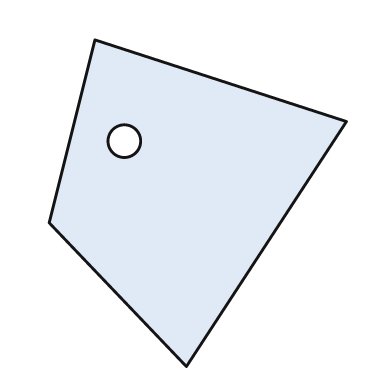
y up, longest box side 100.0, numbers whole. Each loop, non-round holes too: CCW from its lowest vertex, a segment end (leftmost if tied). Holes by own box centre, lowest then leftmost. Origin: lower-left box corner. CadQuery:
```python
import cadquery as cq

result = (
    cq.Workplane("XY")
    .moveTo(42.0, 0.0)
    .lineTo(91.0, 75.0)
    .lineTo(14.0, 100.0)
    .lineTo(0.0, 44.0)
    .close()
    .moveTo(23.0, 69.0)
    .circle(5.0)
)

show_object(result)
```